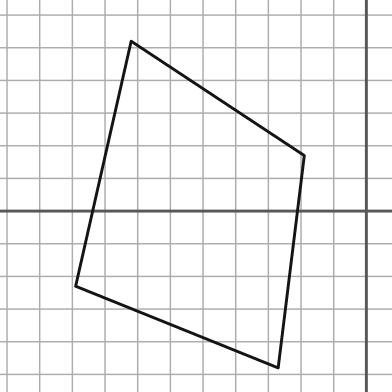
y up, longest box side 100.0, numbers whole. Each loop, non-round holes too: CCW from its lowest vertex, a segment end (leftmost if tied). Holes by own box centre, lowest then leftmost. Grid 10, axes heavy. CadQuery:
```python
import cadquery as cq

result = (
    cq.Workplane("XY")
    .moveTo(-27.0, -48.0)
    .lineTo(-19.0, 17.0)
    .lineTo(-72.0, 52.0)
    .lineTo(-89.0, -23.0)
    .close()
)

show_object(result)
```